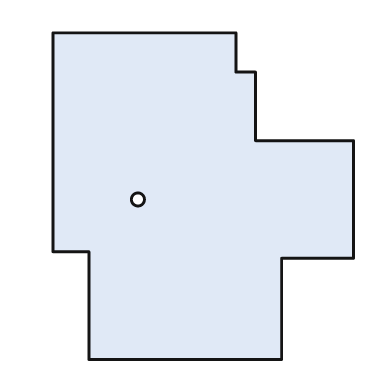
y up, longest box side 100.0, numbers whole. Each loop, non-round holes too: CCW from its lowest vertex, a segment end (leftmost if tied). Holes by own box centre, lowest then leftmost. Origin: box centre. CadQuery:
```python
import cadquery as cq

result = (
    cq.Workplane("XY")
    .moveTo(-35.0, -50.0)
    .lineTo(24.0, -50.0)
    .lineTo(24.0, -19.0)
    .lineTo(46.0, -19.0)
    .lineTo(46.0, 17.0)
    .lineTo(16.0, 17.0)
    .lineTo(16.0, 38.0)
    .lineTo(10.0, 38.0)
    .lineTo(10.0, 50.0)
    .lineTo(-46.0, 50.0)
    .lineTo(-46.0, -17.0)
    .lineTo(-35.0, -17.0)
    .close()
    .moveTo(-20.0, -1.0)
    .circle(2.0)
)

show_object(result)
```